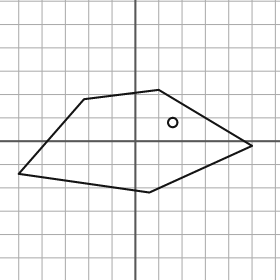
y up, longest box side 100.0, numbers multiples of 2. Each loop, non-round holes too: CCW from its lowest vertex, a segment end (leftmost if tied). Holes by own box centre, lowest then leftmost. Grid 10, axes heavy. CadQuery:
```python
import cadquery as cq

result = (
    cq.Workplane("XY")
    .moveTo(6.0, -22.0)
    .lineTo(50.0, -2.0)
    .lineTo(10.0, 22.0)
    .lineTo(-22.0, 18.0)
    .lineTo(-50.0, -14.0)
    .close()
    .moveTo(16.0, 8.0)
    .circle(2.0)
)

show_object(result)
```